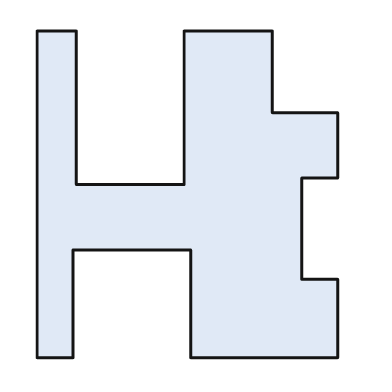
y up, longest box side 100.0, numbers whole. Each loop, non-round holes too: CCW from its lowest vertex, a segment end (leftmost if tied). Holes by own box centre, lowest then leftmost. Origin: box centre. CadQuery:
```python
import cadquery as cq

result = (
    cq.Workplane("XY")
    .moveTo(-46.0, -50.0)
    .lineTo(-35.0, -50.0)
    .lineTo(-35.0, -17.0)
    .lineTo(1.0, -17.0)
    .lineTo(1.0, -50.0)
    .lineTo(46.0, -50.0)
    .lineTo(46.0, -26.0)
    .lineTo(35.0, -26.0)
    .lineTo(35.0, 5.0)
    .lineTo(46.0, 5.0)
    .lineTo(46.0, 25.0)
    .lineTo(26.0, 25.0)
    .lineTo(26.0, 50.0)
    .lineTo(-1.0, 50.0)
    .lineTo(-1.0, 3.0)
    .lineTo(-34.0, 3.0)
    .lineTo(-34.0, 50.0)
    .lineTo(-46.0, 50.0)
    .close()
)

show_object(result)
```